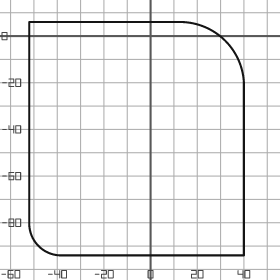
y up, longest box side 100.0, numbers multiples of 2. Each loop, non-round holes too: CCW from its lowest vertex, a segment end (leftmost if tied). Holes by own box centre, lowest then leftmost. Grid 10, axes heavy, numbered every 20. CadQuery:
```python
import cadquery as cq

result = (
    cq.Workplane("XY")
    .moveTo(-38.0, -94.0)
    .lineTo(40.0, -94.0)
    .lineTo(40.0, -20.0)
    .threePointArc((32.0, -2.0), (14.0, 6.0))
    .lineTo(-52.0, 6.0)
    .lineTo(-52.0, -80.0)
    .threePointArc((-48.0, -90.0), (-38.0, -94.0))
    .close()
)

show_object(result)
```